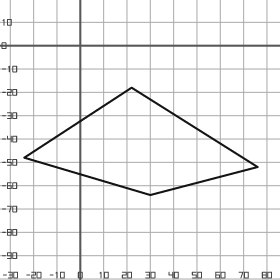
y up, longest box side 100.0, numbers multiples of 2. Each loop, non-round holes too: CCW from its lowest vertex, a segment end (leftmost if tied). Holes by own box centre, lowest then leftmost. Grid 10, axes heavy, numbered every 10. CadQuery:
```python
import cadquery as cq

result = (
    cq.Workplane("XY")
    .moveTo(30.0, -64.0)
    .lineTo(76.0, -52.0)
    .lineTo(22.0, -18.0)
    .lineTo(-24.0, -48.0)
    .close()
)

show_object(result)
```